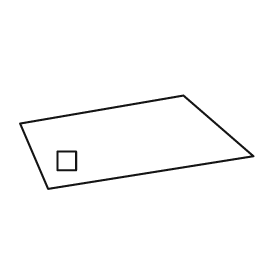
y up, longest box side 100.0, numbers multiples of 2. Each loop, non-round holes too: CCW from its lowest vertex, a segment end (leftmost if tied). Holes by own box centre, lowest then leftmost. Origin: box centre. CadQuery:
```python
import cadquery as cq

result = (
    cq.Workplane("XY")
    .moveTo(-38.0, -20.0)
    .lineTo(50.0, -6.0)
    .lineTo(20.0, 20.0)
    .lineTo(-50.0, 8.0)
    .close()
    .moveTo(-34.0, -12.0)
    .lineTo(-26.0, -12.0)
    .lineTo(-26.0, -4.0)
    .lineTo(-34.0, -4.0)
    .close()
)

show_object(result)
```